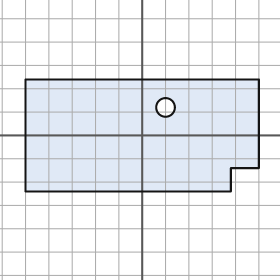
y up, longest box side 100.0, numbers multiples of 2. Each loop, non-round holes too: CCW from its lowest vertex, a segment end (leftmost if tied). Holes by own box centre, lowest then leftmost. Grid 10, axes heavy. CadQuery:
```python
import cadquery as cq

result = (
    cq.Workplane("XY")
    .moveTo(-50.0, -24.0)
    .lineTo(38.0, -24.0)
    .lineTo(38.0, -14.0)
    .lineTo(50.0, -14.0)
    .lineTo(50.0, 24.0)
    .lineTo(-50.0, 24.0)
    .close()
    .moveTo(10.0, 12.0)
    .circle(4.0)
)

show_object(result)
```